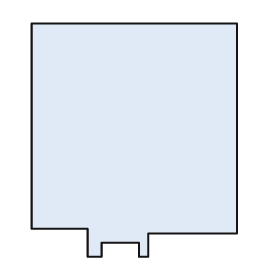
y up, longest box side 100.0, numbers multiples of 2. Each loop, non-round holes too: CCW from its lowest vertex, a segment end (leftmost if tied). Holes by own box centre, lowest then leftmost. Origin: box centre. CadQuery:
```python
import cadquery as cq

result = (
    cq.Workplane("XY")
    .moveTo(-20.0, -50.0)
    .lineTo(-14.0, -50.0)
    .lineTo(-14.0, -44.0)
    .lineTo(2.0, -44.0)
    .lineTo(2.0, -50.0)
    .lineTo(6.0, -50.0)
    .lineTo(6.0, -40.0)
    .lineTo(44.0, -40.0)
    .lineTo(44.0, 50.0)
    .lineTo(-44.0, 50.0)
    .lineTo(-44.0, -38.0)
    .lineTo(-20.0, -38.0)
    .close()
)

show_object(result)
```